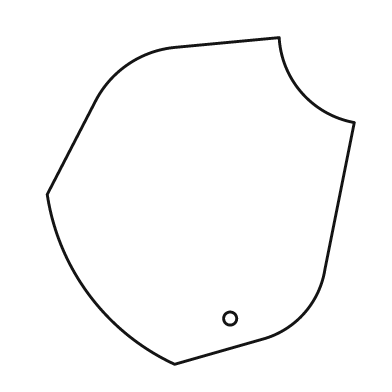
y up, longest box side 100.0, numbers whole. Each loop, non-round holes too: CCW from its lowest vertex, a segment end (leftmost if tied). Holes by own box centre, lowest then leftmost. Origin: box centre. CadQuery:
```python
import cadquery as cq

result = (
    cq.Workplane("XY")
    .moveTo(-8.0, -50.0)
    .lineTo(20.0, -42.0)
    .threePointArc((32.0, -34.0), (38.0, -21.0))
    .lineTo(47.0, 24.0)
    .threePointArc((31.0, 33.0), (24.0, 50.0))
    .lineTo(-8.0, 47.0)
    .threePointArc((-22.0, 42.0), (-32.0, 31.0))
    .lineTo(-47.0, 2.0)
    .threePointArc((-34.0, -29.0), (-8.0, -50.0))
    .close()
    .moveTo(9.0, -36.0)
    .circle(2.0)
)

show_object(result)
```